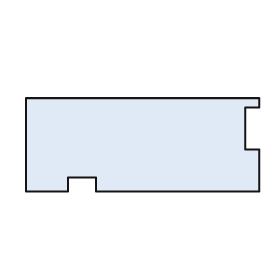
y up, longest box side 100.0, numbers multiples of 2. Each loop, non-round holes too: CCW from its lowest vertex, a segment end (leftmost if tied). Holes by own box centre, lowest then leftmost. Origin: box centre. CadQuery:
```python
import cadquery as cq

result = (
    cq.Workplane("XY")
    .moveTo(-50.0, -20.0)
    .lineTo(-32.0, -20.0)
    .lineTo(-32.0, -14.0)
    .lineTo(-20.0, -14.0)
    .lineTo(-20.0, -20.0)
    .lineTo(50.0, -20.0)
    .lineTo(50.0, -2.0)
    .lineTo(44.0, -2.0)
    .lineTo(44.0, 16.0)
    .lineTo(50.0, 16.0)
    .lineTo(50.0, 20.0)
    .lineTo(-50.0, 20.0)
    .close()
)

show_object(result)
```